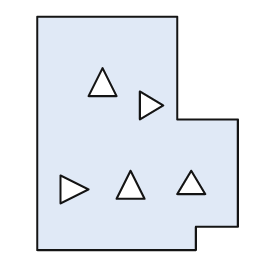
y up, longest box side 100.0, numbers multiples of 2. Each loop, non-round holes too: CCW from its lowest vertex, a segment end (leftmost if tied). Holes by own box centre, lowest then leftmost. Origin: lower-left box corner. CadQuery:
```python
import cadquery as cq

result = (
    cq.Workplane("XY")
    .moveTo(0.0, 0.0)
    .lineTo(68.0, 0.0)
    .lineTo(68.0, 10.0)
    .lineTo(86.0, 10.0)
    .lineTo(86.0, 56.0)
    .lineTo(60.0, 56.0)
    .lineTo(60.0, 100.0)
    .lineTo(0.0, 100.0)
    .close()
    .moveTo(10.0, 20.0)
    .lineTo(22.0, 26.0)
    .lineTo(10.0, 32.0)
    .close()
    .moveTo(34.0, 22.0)
    .lineTo(46.0, 22.0)
    .lineTo(40.0, 34.0)
    .close()
    .moveTo(60.0, 24.0)
    .lineTo(72.0, 24.0)
    .lineTo(66.0, 34.0)
    .close()
    .moveTo(44.0, 56.0)
    .lineTo(54.0, 62.0)
    .lineTo(44.0, 68.0)
    .close()
    .moveTo(22.0, 66.0)
    .lineTo(34.0, 66.0)
    .lineTo(28.0, 78.0)
    .close()
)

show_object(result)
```